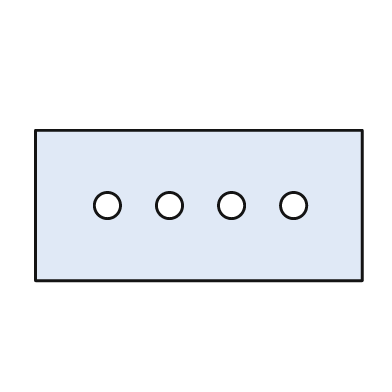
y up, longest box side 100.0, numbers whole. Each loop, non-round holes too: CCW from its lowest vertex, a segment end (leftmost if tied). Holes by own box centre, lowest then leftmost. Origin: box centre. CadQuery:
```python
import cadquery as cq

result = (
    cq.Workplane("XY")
    .moveTo(-50.0, -23.0)
    .lineTo(50.0, -23.0)
    .lineTo(50.0, 23.0)
    .lineTo(-50.0, 23.0)
    .close()
    .moveTo(-28.0, 0.0)
    .circle(4.0)
    .moveTo(-9.0, 0.0)
    .circle(4.0)
    .moveTo(10.0, 0.0)
    .circle(4.0)
    .moveTo(29.0, 0.0)
    .circle(4.0)
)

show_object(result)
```